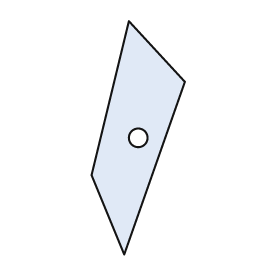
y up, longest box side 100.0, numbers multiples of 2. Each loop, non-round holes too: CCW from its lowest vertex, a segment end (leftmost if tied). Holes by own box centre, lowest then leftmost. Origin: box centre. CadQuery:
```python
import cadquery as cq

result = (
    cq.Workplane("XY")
    .moveTo(-6.0, -50.0)
    .lineTo(20.0, 24.0)
    .lineTo(-4.0, 50.0)
    .lineTo(-20.0, -16.0)
    .close()
    .moveTo(0.0, 0.0)
    .circle(4.0)
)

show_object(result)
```